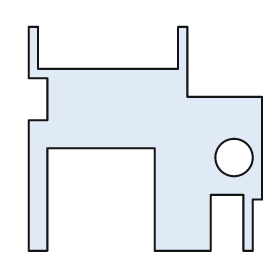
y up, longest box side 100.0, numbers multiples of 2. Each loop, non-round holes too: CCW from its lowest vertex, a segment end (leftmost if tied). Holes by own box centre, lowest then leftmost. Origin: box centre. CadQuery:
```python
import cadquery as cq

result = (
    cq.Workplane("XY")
    .moveTo(-50.0, -48.0)
    .lineTo(-42.0, -48.0)
    .lineTo(-42.0, -4.0)
    .lineTo(4.0, -4.0)
    .lineTo(4.0, -48.0)
    .lineTo(28.0, -48.0)
    .lineTo(28.0, -24.0)
    .lineTo(42.0, -24.0)
    .lineTo(42.0, -48.0)
    .lineTo(46.0, -48.0)
    .lineTo(46.0, -26.0)
    .lineTo(50.0, -26.0)
    .lineTo(50.0, 18.0)
    .lineTo(18.0, 18.0)
    .lineTo(18.0, 48.0)
    .lineTo(14.0, 48.0)
    .lineTo(14.0, 30.0)
    .lineTo(-46.0, 30.0)
    .lineTo(-46.0, 48.0)
    .lineTo(-50.0, 48.0)
    .lineTo(-50.0, 26.0)
    .lineTo(-42.0, 26.0)
    .lineTo(-42.0, 8.0)
    .lineTo(-50.0, 8.0)
    .close()
    .moveTo(38.0, -8.0)
    .circle(8.0)
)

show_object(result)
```